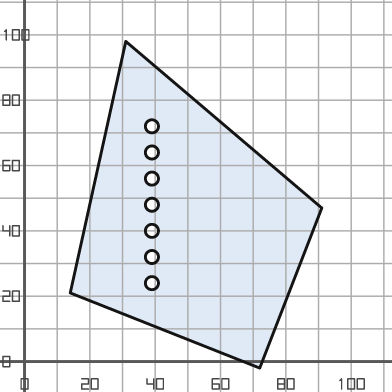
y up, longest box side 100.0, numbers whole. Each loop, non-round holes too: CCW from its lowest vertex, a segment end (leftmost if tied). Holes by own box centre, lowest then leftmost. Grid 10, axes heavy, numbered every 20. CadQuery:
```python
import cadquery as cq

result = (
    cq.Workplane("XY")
    .moveTo(72.0, -2.0)
    .lineTo(91.0, 47.0)
    .lineTo(31.0, 98.0)
    .lineTo(14.0, 21.0)
    .close()
    .moveTo(39.0, 24.0)
    .circle(2.0)
    .moveTo(39.0, 32.0)
    .circle(2.0)
    .moveTo(39.0, 40.0)
    .circle(2.0)
    .moveTo(39.0, 48.0)
    .circle(2.0)
    .moveTo(39.0, 56.0)
    .circle(2.0)
    .moveTo(39.0, 64.0)
    .circle(2.0)
    .moveTo(39.0, 72.0)
    .circle(2.0)
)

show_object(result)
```